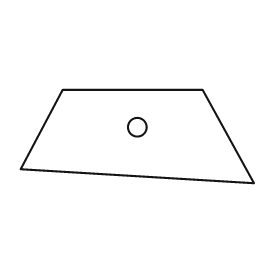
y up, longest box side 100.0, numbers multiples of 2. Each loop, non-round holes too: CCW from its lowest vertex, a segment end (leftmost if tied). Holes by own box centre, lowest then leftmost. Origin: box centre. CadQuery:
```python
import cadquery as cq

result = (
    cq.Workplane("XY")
    .moveTo(50.0, -20.0)
    .lineTo(28.0, 20.0)
    .lineTo(-32.0, 20.0)
    .lineTo(-50.0, -14.0)
    .close()
    .moveTo(0.0, 4.0)
    .circle(4.0)
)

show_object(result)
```